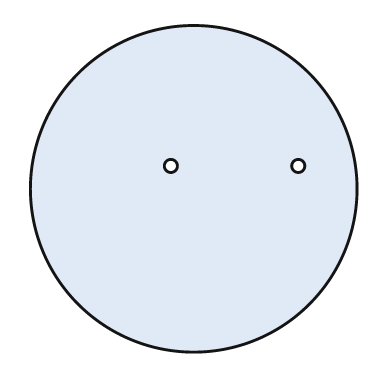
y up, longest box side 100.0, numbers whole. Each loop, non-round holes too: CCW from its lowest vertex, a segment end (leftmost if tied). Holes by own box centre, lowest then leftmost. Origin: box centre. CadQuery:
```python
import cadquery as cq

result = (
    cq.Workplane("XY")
    .moveTo(0.0, 0.0)
    .circle(50.0)
    .moveTo(-7.0, 7.0)
    .circle(2.0)
    .moveTo(32.0, 7.0)
    .circle(2.0)
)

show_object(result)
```